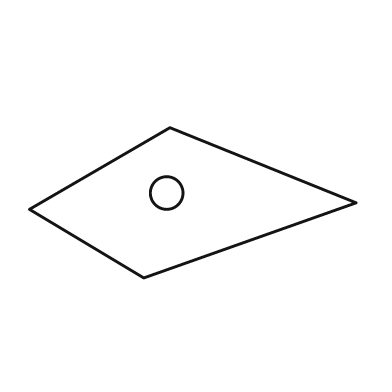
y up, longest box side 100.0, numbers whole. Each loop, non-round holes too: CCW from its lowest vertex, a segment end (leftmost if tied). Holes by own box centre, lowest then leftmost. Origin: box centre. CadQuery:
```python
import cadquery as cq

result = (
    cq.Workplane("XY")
    .moveTo(-15.0, -23.0)
    .lineTo(50.0, 0.0)
    .lineTo(-7.0, 23.0)
    .lineTo(-50.0, -2.0)
    .close()
    .moveTo(-8.0, 3.0)
    .circle(5.0)
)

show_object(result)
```